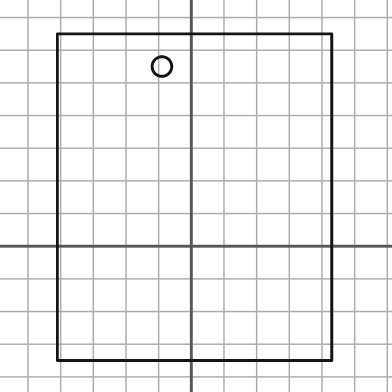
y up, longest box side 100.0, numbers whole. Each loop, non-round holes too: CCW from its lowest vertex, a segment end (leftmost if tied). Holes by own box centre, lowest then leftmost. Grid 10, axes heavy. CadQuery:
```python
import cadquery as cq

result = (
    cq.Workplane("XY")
    .moveTo(-41.0, -35.0)
    .lineTo(43.0, -35.0)
    .lineTo(43.0, 65.0)
    .lineTo(-41.0, 65.0)
    .close()
    .moveTo(-9.0, 55.0)
    .circle(3.0)
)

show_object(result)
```